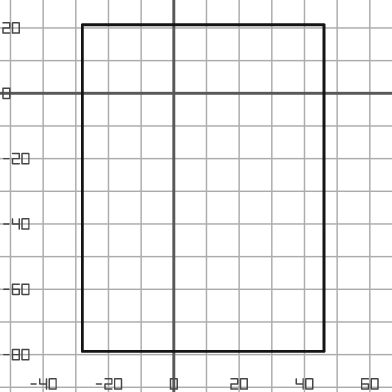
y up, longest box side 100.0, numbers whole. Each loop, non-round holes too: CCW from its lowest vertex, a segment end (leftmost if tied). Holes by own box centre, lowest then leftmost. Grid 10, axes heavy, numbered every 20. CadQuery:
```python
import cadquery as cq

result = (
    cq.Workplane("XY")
    .moveTo(-28.0, -79.0)
    .lineTo(46.0, -79.0)
    .lineTo(46.0, 21.0)
    .lineTo(-28.0, 21.0)
    .close()
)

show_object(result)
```